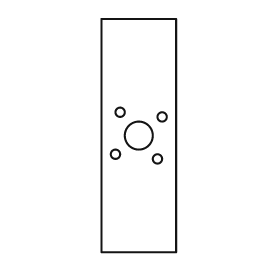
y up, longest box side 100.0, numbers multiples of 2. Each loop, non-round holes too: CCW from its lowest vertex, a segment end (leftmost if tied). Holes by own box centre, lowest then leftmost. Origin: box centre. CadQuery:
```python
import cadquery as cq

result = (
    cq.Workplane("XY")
    .moveTo(-16.0, -50.0)
    .lineTo(16.0, -50.0)
    .lineTo(16.0, 50.0)
    .lineTo(-16.0, 50.0)
    .close()
    .moveTo(8.0, -10.0)
    .circle(2.0)
    .moveTo(-10.0, -8.0)
    .circle(2.0)
    .moveTo(0.0, 0.0)
    .circle(6.0)
    .moveTo(10.0, 8.0)
    .circle(2.0)
    .moveTo(-8.0, 10.0)
    .circle(2.0)
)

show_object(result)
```